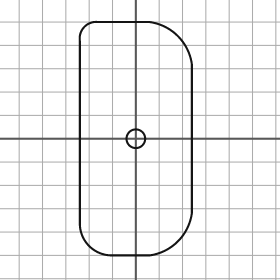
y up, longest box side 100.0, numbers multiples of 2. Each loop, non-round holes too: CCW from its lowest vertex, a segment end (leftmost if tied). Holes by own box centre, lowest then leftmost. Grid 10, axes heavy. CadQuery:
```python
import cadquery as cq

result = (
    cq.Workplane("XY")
    .moveTo(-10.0, -50.0)
    .lineTo(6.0, -50.0)
    .threePointArc((18.0, -44.0), (24.0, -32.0))
    .lineTo(24.0, 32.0)
    .threePointArc((18.0, 44.0), (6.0, 50.0))
    .lineTo(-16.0, 50.0)
    .threePointArc((-22.0, 48.0), (-24.0, 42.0))
    .lineTo(-24.0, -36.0)
    .threePointArc((-20.0, -46.0), (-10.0, -50.0))
    .close()
    .moveTo(0.0, 0.0)
    .circle(4.0)
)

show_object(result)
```